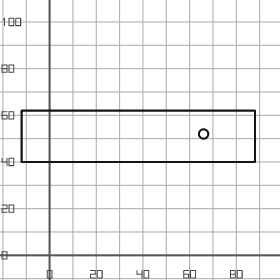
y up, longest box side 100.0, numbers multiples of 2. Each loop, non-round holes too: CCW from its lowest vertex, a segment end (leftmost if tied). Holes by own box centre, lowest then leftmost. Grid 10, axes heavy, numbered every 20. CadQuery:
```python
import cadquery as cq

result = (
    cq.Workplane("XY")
    .moveTo(-12.0, 40.0)
    .lineTo(88.0, 40.0)
    .lineTo(88.0, 62.0)
    .lineTo(-12.0, 62.0)
    .close()
    .moveTo(66.0, 52.0)
    .circle(2.0)
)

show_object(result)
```